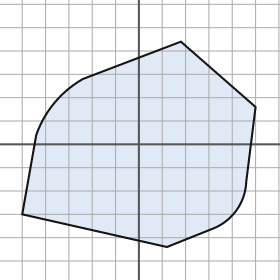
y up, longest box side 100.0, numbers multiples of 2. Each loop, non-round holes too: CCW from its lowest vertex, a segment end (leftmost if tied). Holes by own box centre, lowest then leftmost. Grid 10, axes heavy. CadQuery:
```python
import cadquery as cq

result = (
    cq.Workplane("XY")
    .moveTo(12.0, -44.0)
    .lineTo(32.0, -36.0)
    .threePointArc((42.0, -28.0), (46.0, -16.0))
    .lineTo(50.0, 16.0)
    .lineTo(18.0, 44.0)
    .lineTo(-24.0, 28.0)
    .threePointArc((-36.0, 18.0), (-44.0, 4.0))
    .lineTo(-50.0, -30.0)
    .close()
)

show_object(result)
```